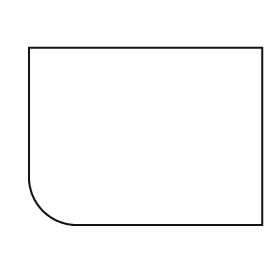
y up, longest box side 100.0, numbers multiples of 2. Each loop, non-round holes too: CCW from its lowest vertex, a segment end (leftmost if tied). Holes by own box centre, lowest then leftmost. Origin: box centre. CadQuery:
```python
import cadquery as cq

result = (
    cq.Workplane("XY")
    .moveTo(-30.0, -38.0)
    .lineTo(50.0, -38.0)
    .lineTo(50.0, 38.0)
    .lineTo(-50.0, 38.0)
    .lineTo(-50.0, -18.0)
    .threePointArc((-44.0, -32.0), (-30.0, -38.0))
    .close()
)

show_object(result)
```